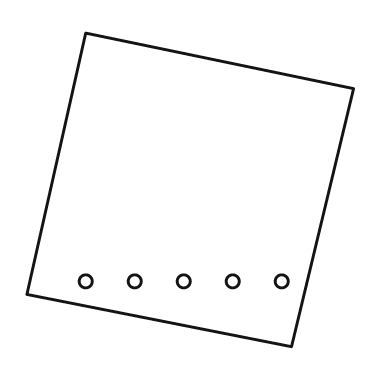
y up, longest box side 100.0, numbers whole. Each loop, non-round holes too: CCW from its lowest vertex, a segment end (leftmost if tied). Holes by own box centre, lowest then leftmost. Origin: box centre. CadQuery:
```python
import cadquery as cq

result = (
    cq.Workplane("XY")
    .moveTo(31.0, -48.0)
    .lineTo(50.0, 31.0)
    .lineTo(-32.0, 48.0)
    .lineTo(-50.0, -32.0)
    .close()
    .moveTo(-32.0, -28.0)
    .circle(2.0)
    .moveTo(-17.0, -28.0)
    .circle(2.0)
    .moveTo(-2.0, -28.0)
    .circle(2.0)
    .moveTo(13.0, -28.0)
    .circle(2.0)
    .moveTo(28.0, -28.0)
    .circle(2.0)
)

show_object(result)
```